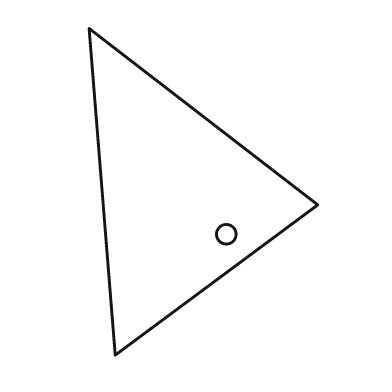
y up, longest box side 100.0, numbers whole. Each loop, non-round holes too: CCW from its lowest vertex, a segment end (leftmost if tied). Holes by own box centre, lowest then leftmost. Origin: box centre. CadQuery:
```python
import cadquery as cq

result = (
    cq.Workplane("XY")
    .moveTo(-27.0, -50.0)
    .lineTo(35.0, -4.0)
    .lineTo(-35.0, 50.0)
    .close()
    .moveTo(7.0, -13.0)
    .circle(3.0)
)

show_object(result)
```